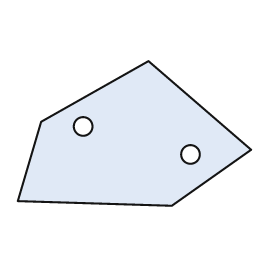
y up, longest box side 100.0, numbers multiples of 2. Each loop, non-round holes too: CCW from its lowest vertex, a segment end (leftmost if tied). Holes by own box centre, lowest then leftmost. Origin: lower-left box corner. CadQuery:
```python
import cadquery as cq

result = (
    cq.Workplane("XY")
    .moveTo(66.0, 0.0)
    .lineTo(100.0, 24.0)
    .lineTo(56.0, 62.0)
    .lineTo(10.0, 36.0)
    .lineTo(0.0, 2.0)
    .close()
    .moveTo(74.0, 22.0)
    .circle(4.0)
    .moveTo(28.0, 34.0)
    .circle(4.0)
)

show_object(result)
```